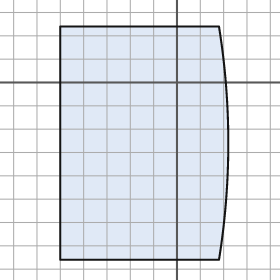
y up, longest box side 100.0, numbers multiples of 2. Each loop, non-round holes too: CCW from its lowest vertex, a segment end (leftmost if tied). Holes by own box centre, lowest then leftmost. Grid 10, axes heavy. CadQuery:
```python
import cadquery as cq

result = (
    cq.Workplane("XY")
    .moveTo(-50.0, -76.0)
    .lineTo(18.0, -76.0)
    .threePointArc((22.0, -26.0), (18.0, 24.0))
    .lineTo(-50.0, 24.0)
    .close()
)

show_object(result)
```